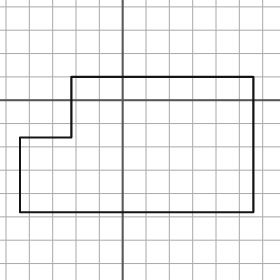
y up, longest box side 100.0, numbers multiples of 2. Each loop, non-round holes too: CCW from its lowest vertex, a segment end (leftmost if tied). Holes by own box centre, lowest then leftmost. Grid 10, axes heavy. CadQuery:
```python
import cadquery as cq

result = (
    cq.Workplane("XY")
    .moveTo(-44.0, -48.0)
    .lineTo(56.0, -48.0)
    .lineTo(56.0, 10.0)
    .lineTo(-22.0, 10.0)
    .lineTo(-22.0, -16.0)
    .lineTo(-44.0, -16.0)
    .close()
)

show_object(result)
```